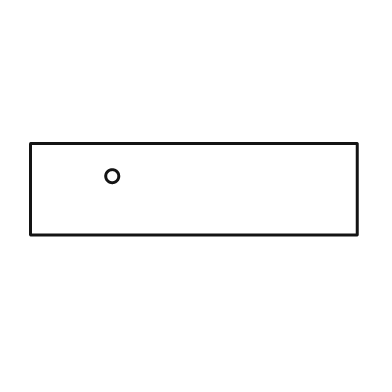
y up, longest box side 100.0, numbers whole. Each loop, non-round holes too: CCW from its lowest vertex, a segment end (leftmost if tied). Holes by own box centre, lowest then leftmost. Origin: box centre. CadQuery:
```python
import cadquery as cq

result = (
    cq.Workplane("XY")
    .moveTo(-50.0, -14.0)
    .lineTo(50.0, -14.0)
    .lineTo(50.0, 14.0)
    .lineTo(-50.0, 14.0)
    .close()
    .moveTo(-25.0, 4.0)
    .circle(2.0)
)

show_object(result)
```